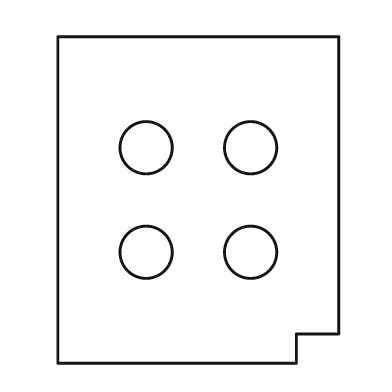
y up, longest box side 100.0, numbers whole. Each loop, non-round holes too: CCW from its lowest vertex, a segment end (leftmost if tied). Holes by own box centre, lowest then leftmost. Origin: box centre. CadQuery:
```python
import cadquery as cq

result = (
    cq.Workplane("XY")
    .moveTo(-43.0, -50.0)
    .lineTo(30.0, -50.0)
    .lineTo(30.0, -41.0)
    .lineTo(43.0, -41.0)
    .lineTo(43.0, 50.0)
    .lineTo(-43.0, 50.0)
    .close()
    .moveTo(-16.0, -16.0)
    .circle(8.0)
    .moveTo(16.0, -16.0)
    .circle(8.0)
    .moveTo(-16.0, 16.0)
    .circle(8.0)
    .moveTo(16.0, 16.0)
    .circle(8.0)
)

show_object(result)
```